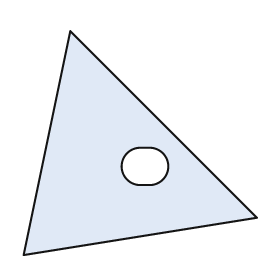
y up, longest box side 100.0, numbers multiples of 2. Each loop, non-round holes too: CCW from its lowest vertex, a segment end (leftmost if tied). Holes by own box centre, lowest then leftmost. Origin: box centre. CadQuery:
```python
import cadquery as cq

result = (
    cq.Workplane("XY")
    .moveTo(-50.0, -48.0)
    .lineTo(50.0, -32.0)
    .lineTo(-30.0, 48.0)
    .close()
    .moveTo(0.0, -18.0)
    .lineTo(4.0, -18.0)
    .threePointArc((12.0, -10.0), (4.0, -2.0))
    .lineTo(0.0, -2.0)
    .threePointArc((-8.0, -10.0), (0.0, -18.0))
    .close()
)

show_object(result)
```